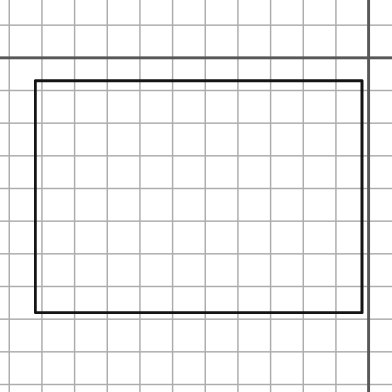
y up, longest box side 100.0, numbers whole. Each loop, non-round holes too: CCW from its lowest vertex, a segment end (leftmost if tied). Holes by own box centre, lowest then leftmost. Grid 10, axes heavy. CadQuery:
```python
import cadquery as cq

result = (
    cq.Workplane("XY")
    .moveTo(-102.0, -78.0)
    .lineTo(-2.0, -78.0)
    .lineTo(-2.0, -7.0)
    .lineTo(-102.0, -7.0)
    .close()
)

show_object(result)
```